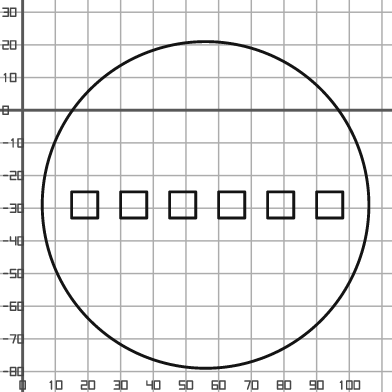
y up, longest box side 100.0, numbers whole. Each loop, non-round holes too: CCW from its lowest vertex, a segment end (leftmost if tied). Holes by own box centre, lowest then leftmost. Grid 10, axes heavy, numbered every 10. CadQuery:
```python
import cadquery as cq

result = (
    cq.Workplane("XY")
    .moveTo(56.0, -29.0)
    .circle(50.0)
    .moveTo(15.0, -33.0)
    .lineTo(23.0, -33.0)
    .lineTo(23.0, -25.0)
    .lineTo(15.0, -25.0)
    .close()
    .moveTo(30.0, -33.0)
    .lineTo(38.0, -33.0)
    .lineTo(38.0, -25.0)
    .lineTo(30.0, -25.0)
    .close()
    .moveTo(45.0, -33.0)
    .lineTo(53.0, -33.0)
    .lineTo(53.0, -25.0)
    .lineTo(45.0, -25.0)
    .close()
    .moveTo(60.0, -33.0)
    .lineTo(68.0, -33.0)
    .lineTo(68.0, -25.0)
    .lineTo(60.0, -25.0)
    .close()
    .moveTo(75.0, -33.0)
    .lineTo(83.0, -33.0)
    .lineTo(83.0, -25.0)
    .lineTo(75.0, -25.0)
    .close()
    .moveTo(90.0, -33.0)
    .lineTo(98.0, -33.0)
    .lineTo(98.0, -25.0)
    .lineTo(90.0, -25.0)
    .close()
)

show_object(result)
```